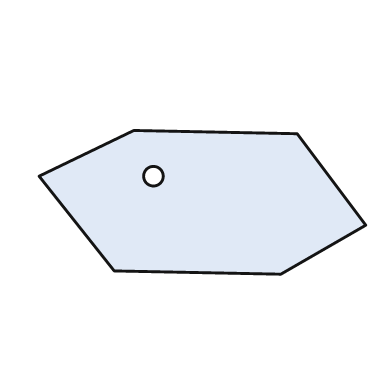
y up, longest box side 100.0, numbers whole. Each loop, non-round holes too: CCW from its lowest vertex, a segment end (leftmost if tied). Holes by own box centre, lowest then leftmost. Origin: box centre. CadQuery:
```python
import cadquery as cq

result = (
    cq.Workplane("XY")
    .moveTo(24.0, -22.0)
    .lineTo(50.0, -7.0)
    .lineTo(29.0, 21.0)
    .lineTo(-21.0, 22.0)
    .lineTo(-50.0, 8.0)
    .lineTo(-27.0, -21.0)
    .close()
    .moveTo(-15.0, 8.0)
    .circle(3.0)
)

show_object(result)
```